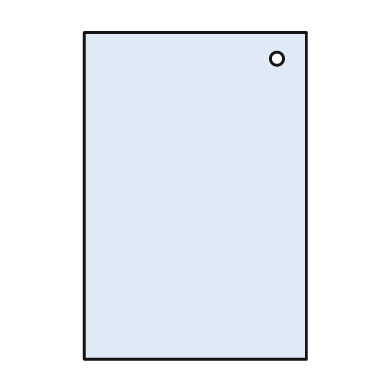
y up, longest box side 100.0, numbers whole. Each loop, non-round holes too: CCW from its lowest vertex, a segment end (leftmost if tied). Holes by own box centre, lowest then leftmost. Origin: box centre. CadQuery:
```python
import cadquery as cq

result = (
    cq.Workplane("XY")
    .moveTo(-34.0, -50.0)
    .lineTo(34.0, -50.0)
    .lineTo(34.0, 50.0)
    .lineTo(-34.0, 50.0)
    .close()
    .moveTo(25.0, 42.0)
    .circle(2.0)
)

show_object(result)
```